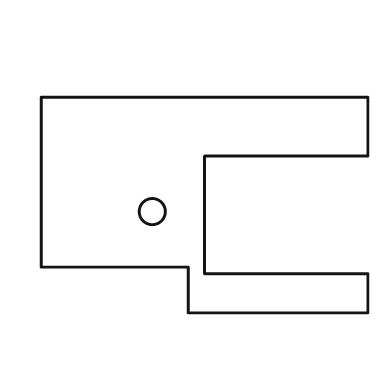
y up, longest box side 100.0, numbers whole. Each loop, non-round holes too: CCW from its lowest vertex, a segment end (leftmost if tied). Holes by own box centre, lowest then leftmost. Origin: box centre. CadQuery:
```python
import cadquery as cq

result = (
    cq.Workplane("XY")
    .moveTo(-5.0, -33.0)
    .lineTo(50.0, -33.0)
    .lineTo(50.0, -21.0)
    .lineTo(0.0, -21.0)
    .lineTo(0.0, 15.0)
    .lineTo(50.0, 15.0)
    .lineTo(50.0, 33.0)
    .lineTo(-50.0, 33.0)
    .lineTo(-50.0, -19.0)
    .lineTo(-5.0, -19.0)
    .close()
    .moveTo(-16.0, -2.0)
    .circle(4.0)
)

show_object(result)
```